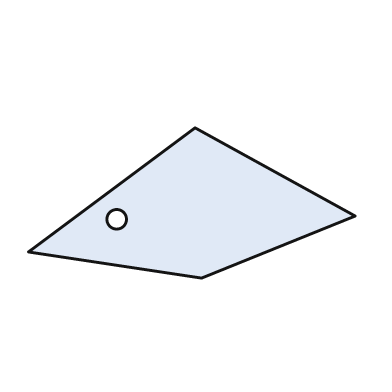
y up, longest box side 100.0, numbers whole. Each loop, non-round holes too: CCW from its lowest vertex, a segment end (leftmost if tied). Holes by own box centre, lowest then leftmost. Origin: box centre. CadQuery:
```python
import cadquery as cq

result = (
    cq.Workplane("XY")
    .moveTo(3.0, -23.0)
    .lineTo(50.0, -4.0)
    .lineTo(1.0, 23.0)
    .lineTo(-50.0, -15.0)
    .close()
    .moveTo(-23.0, -5.0)
    .circle(3.0)
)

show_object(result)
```